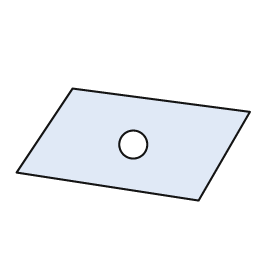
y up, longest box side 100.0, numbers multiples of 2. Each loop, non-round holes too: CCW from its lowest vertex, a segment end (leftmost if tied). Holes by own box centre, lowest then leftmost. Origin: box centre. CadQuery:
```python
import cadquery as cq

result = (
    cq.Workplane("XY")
    .moveTo(28.0, -24.0)
    .lineTo(50.0, 14.0)
    .lineTo(-26.0, 24.0)
    .lineTo(-50.0, -12.0)
    .close()
    .moveTo(0.0, 0.0)
    .circle(6.0)
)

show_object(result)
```